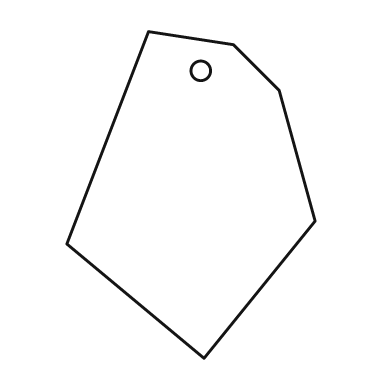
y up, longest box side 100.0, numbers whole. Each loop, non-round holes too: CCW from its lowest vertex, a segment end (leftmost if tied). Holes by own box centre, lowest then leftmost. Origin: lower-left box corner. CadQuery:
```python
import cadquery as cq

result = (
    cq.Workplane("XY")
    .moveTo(42.0, 0.0)
    .lineTo(76.0, 42.0)
    .lineTo(65.0, 82.0)
    .lineTo(51.0, 96.0)
    .lineTo(25.0, 100.0)
    .lineTo(0.0, 35.0)
    .close()
    .moveTo(41.0, 88.0)
    .circle(3.0)
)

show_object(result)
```